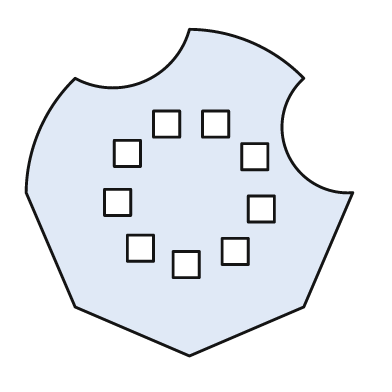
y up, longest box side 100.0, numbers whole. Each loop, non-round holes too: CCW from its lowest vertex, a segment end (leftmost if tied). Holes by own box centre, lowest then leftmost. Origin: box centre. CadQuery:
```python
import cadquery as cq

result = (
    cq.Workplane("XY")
    .moveTo(0.0, -50.0)
    .lineTo(35.0, -35.0)
    .lineTo(50.0, 0.0)
    .threePointArc((30.0, 12.0), (35.0, 35.0))
    .threePointArc((19.0, 46.0), (0.0, 50.0))
    .threePointArc((-14.0, 34.0), (-35.0, 35.0))
    .threePointArc((-46.0, 19.0), (-50.0, 0.0))
    .lineTo(-35.0, -35.0)
    .close()
    .moveTo(-5.0, -26.0)
    .lineTo(3.0, -26.0)
    .lineTo(3.0, -18.0)
    .lineTo(-5.0, -18.0)
    .close()
    .moveTo(10.0, -22.0)
    .lineTo(18.0, -22.0)
    .lineTo(18.0, -14.0)
    .lineTo(10.0, -14.0)
    .close()
    .moveTo(-19.0, -21.0)
    .lineTo(-11.0, -21.0)
    .lineTo(-11.0, -13.0)
    .lineTo(-19.0, -13.0)
    .close()
    .moveTo(18.0, -9.0)
    .lineTo(26.0, -9.0)
    .lineTo(26.0, -1.0)
    .lineTo(18.0, -1.0)
    .close()
    .moveTo(-26.0, -7.0)
    .lineTo(-18.0, -7.0)
    .lineTo(-18.0, 1.0)
    .lineTo(-26.0, 1.0)
    .close()
    .moveTo(16.0, 7.0)
    .lineTo(24.0, 7.0)
    .lineTo(24.0, 15.0)
    .lineTo(16.0, 15.0)
    .close()
    .moveTo(-23.0, 8.0)
    .lineTo(-15.0, 8.0)
    .lineTo(-15.0, 16.0)
    .lineTo(-23.0, 16.0)
    .close()
    .moveTo(-11.0, 17.0)
    .lineTo(-3.0, 17.0)
    .lineTo(-3.0, 25.0)
    .lineTo(-11.0, 25.0)
    .close()
    .moveTo(4.0, 17.0)
    .lineTo(12.0, 17.0)
    .lineTo(12.0, 25.0)
    .lineTo(4.0, 25.0)
    .close()
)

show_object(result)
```